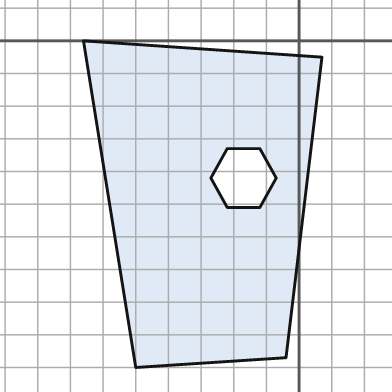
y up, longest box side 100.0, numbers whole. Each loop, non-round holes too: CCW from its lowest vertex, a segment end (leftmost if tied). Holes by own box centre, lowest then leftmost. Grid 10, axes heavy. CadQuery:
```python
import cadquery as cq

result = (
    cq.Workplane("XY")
    .moveTo(-50.0, -100.0)
    .lineTo(-4.0, -97.0)
    .lineTo(7.0, -5.0)
    .lineTo(-66.0, 0.0)
    .close()
    .moveTo(-22.0, -51.0)
    .lineTo(-12.0, -51.0)
    .lineTo(-7.0, -42.0)
    .lineTo(-12.0, -33.0)
    .lineTo(-22.0, -33.0)
    .lineTo(-27.0, -42.0)
    .close()
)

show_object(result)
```